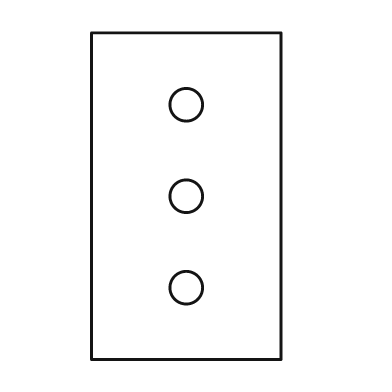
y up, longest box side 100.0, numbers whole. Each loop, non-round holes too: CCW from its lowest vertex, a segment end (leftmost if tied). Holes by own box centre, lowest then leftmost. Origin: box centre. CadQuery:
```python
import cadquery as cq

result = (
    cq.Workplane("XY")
    .moveTo(-29.0, -50.0)
    .lineTo(29.0, -50.0)
    .lineTo(29.0, 50.0)
    .lineTo(-29.0, 50.0)
    .close()
    .moveTo(0.0, -28.0)
    .circle(5.0)
    .moveTo(0.0, 0.0)
    .circle(5.0)
    .moveTo(0.0, 28.0)
    .circle(5.0)
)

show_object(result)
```